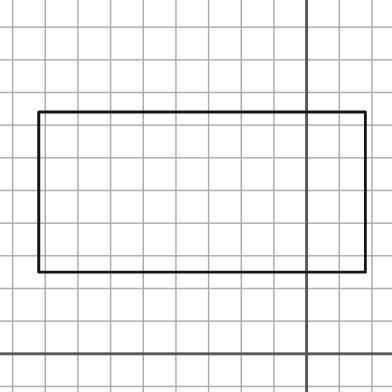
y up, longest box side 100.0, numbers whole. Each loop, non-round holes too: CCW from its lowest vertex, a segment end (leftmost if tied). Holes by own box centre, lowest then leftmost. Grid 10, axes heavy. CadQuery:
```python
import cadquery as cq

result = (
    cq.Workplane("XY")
    .moveTo(-82.0, 25.0)
    .lineTo(18.0, 25.0)
    .lineTo(18.0, 74.0)
    .lineTo(-82.0, 74.0)
    .close()
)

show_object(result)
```